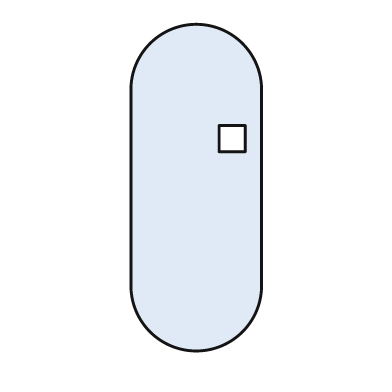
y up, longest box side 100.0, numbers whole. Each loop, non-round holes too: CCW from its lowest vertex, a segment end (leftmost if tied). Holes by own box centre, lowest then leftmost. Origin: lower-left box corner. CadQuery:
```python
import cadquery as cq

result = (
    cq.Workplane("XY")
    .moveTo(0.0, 20.0)
    .threePointArc((20.0, 0.0), (40.0, 20.0))
    .lineTo(40.0, 80.0)
    .threePointArc((20.0, 100.0), (0.0, 80.0))
    .close()
    .moveTo(27.0, 61.0)
    .lineTo(35.0, 61.0)
    .lineTo(35.0, 69.0)
    .lineTo(27.0, 69.0)
    .close()
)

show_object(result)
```